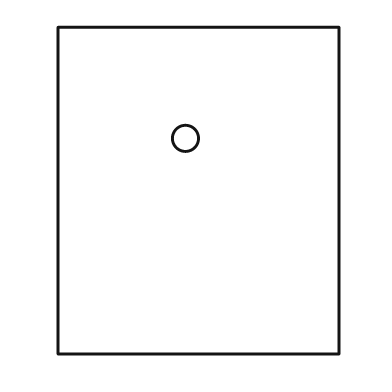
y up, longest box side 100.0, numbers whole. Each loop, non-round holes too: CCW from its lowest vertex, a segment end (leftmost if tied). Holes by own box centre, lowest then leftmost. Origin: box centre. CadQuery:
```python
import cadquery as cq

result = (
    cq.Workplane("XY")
    .moveTo(-43.0, -50.0)
    .lineTo(43.0, -50.0)
    .lineTo(43.0, 50.0)
    .lineTo(-43.0, 50.0)
    .close()
    .moveTo(-4.0, 16.0)
    .circle(4.0)
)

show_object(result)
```